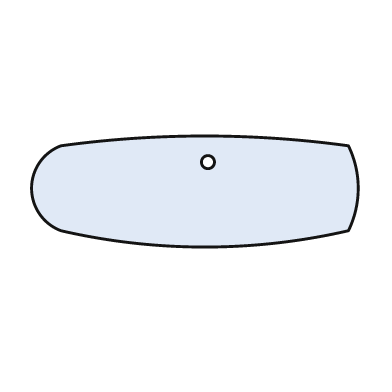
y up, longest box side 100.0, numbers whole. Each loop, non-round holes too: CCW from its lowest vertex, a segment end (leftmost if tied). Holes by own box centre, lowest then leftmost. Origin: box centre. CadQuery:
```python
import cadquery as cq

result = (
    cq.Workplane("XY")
    .moveTo(-41.0, -12.0)
    .threePointArc((3.0, -17.0), (47.0, -12.0))
    .threePointArc((50.0, 1.0), (47.0, 14.0))
    .threePointArc((3.0, 17.0), (-41.0, 14.0))
    .threePointArc((-50.0, 1.0), (-41.0, -12.0))
    .close()
    .moveTo(4.0, 9.0)
    .circle(2.0)
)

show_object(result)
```